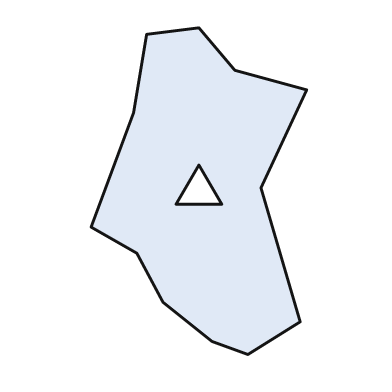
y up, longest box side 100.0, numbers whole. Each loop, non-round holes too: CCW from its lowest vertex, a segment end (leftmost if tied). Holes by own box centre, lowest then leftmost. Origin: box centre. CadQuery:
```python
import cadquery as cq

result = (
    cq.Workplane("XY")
    .moveTo(15.0, -50.0)
    .lineTo(31.0, -40.0)
    .lineTo(19.0, 1.0)
    .lineTo(33.0, 31.0)
    .lineTo(11.0, 37.0)
    .lineTo(0.0, 50.0)
    .lineTo(-16.0, 48.0)
    .lineTo(-20.0, 24.0)
    .lineTo(-33.0, -11.0)
    .lineTo(-19.0, -19.0)
    .lineTo(-11.0, -34.0)
    .lineTo(4.0, -46.0)
    .close()
    .moveTo(-7.0, -4.0)
    .lineTo(7.0, -4.0)
    .lineTo(0.0, 8.0)
    .close()
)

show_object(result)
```